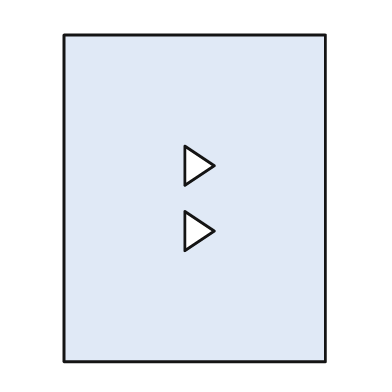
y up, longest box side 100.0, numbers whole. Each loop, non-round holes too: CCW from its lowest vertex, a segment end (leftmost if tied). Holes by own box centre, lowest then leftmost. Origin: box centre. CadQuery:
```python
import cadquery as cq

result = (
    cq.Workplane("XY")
    .moveTo(-40.0, -50.0)
    .lineTo(40.0, -50.0)
    .lineTo(40.0, 50.0)
    .lineTo(-40.0, 50.0)
    .close()
    .moveTo(-3.0, -16.0)
    .lineTo(6.0, -10.0)
    .lineTo(-3.0, -4.0)
    .close()
    .moveTo(-3.0, 4.0)
    .lineTo(6.0, 10.0)
    .lineTo(-3.0, 16.0)
    .close()
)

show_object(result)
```